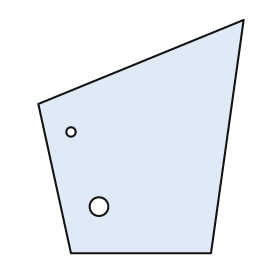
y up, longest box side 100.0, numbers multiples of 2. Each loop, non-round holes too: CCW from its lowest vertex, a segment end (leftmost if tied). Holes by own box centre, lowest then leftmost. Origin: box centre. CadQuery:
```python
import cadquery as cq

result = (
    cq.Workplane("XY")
    .moveTo(-30.0, -50.0)
    .lineTo(30.0, -50.0)
    .lineTo(44.0, 50.0)
    .lineTo(-44.0, 14.0)
    .close()
    .moveTo(-18.0, -30.0)
    .circle(4.0)
    .moveTo(-30.0, 2.0)
    .circle(2.0)
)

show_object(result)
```